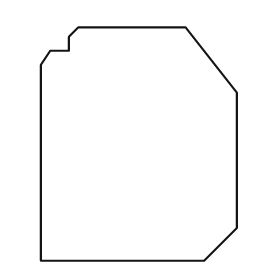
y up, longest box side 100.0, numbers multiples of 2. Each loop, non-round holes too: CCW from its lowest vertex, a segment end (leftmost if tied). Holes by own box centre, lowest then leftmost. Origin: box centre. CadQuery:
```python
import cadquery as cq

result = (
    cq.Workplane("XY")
    .moveTo(-42.0, -50.0)
    .lineTo(28.0, -50.0)
    .lineTo(42.0, -36.0)
    .lineTo(42.0, 22.0)
    .lineTo(20.0, 50.0)
    .lineTo(-26.0, 50.0)
    .lineTo(-30.0, 46.0)
    .lineTo(-30.0, 40.0)
    .lineTo(-38.0, 40.0)
    .lineTo(-42.0, 34.0)
    .close()
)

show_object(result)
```